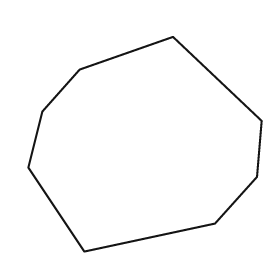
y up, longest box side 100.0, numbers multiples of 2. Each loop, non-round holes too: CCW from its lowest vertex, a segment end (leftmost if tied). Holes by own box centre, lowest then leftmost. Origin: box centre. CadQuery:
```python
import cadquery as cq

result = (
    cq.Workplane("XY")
    .moveTo(-26.0, -46.0)
    .lineTo(30.0, -34.0)
    .lineTo(48.0, -14.0)
    .lineTo(50.0, 10.0)
    .lineTo(12.0, 46.0)
    .lineTo(-28.0, 32.0)
    .lineTo(-44.0, 14.0)
    .lineTo(-50.0, -10.0)
    .close()
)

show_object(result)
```